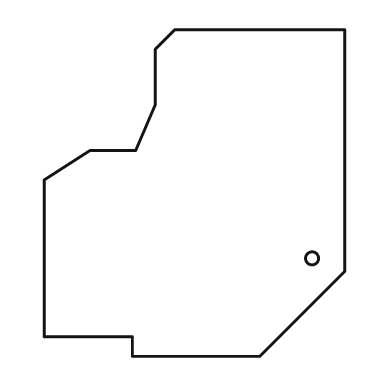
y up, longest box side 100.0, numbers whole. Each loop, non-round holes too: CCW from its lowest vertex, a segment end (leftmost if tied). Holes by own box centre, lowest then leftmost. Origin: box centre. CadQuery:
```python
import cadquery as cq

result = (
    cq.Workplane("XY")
    .moveTo(-19.0, -50.0)
    .lineTo(20.0, -50.0)
    .lineTo(46.0, -24.0)
    .lineTo(46.0, 50.0)
    .lineTo(-6.0, 50.0)
    .lineTo(-12.0, 44.0)
    .lineTo(-12.0, 27.0)
    .lineTo(-18.0, 13.0)
    .lineTo(-32.0, 13.0)
    .lineTo(-46.0, 4.0)
    .lineTo(-46.0, -44.0)
    .lineTo(-19.0, -44.0)
    .close()
    .moveTo(36.0, -20.0)
    .circle(2.0)
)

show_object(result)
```